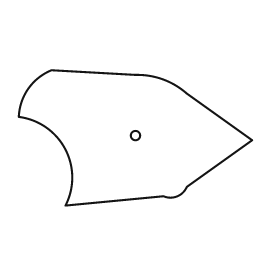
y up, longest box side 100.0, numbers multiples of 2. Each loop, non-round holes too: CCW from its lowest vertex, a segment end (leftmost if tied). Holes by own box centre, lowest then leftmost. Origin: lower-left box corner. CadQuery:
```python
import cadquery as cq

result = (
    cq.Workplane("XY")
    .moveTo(20.0, 0.0)
    .lineTo(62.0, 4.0)
    .threePointArc((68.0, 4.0), (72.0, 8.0))
    .lineTo(100.0, 28.0)
    .lineTo(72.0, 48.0)
    .threePointArc((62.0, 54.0), (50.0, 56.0))
    .lineTo(14.0, 58.0)
    .threePointArc((4.0, 50.0), (0.0, 38.0))
    .threePointArc((20.0, 24.0), (20.0, 0.0))
    .close()
    .moveTo(50.0, 30.0)
    .circle(2.0)
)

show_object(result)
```